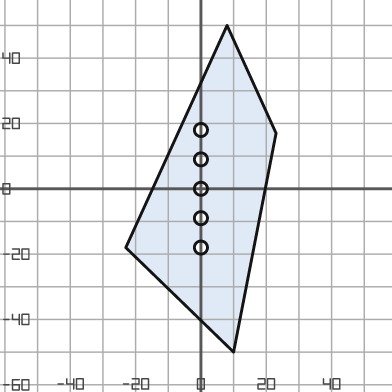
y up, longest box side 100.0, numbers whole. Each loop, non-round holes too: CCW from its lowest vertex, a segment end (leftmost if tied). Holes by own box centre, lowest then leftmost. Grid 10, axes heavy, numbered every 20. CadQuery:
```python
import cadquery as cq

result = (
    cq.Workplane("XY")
    .moveTo(10.0, -50.0)
    .lineTo(23.0, 17.0)
    .lineTo(8.0, 50.0)
    .lineTo(-23.0, -18.0)
    .close()
    .moveTo(0.0, -18.0)
    .circle(2.0)
    .moveTo(0.0, -9.0)
    .circle(2.0)
    .moveTo(0.0, 0.0)
    .circle(2.0)
    .moveTo(0.0, 9.0)
    .circle(2.0)
    .moveTo(0.0, 18.0)
    .circle(2.0)
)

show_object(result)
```